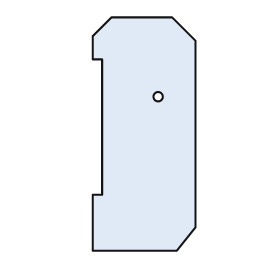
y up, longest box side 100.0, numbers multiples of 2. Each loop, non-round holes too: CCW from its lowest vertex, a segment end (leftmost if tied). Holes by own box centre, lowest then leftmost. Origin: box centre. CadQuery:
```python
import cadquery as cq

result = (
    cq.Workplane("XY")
    .moveTo(-22.0, -50.0)
    .lineTo(14.0, -50.0)
    .lineTo(22.0, -40.0)
    .lineTo(22.0, 40.0)
    .lineTo(12.0, 50.0)
    .lineTo(-14.0, 50.0)
    .lineTo(-22.0, 42.0)
    .lineTo(-22.0, 32.0)
    .lineTo(-18.0, 32.0)
    .lineTo(-18.0, -26.0)
    .lineTo(-22.0, -26.0)
    .close()
    .moveTo(6.0, 16.0)
    .circle(2.0)
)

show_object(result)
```